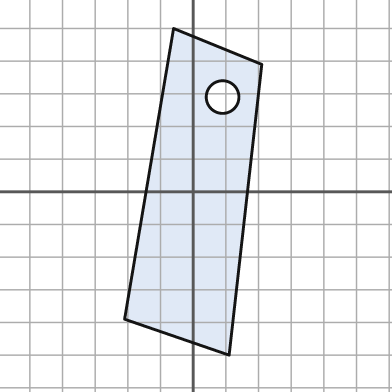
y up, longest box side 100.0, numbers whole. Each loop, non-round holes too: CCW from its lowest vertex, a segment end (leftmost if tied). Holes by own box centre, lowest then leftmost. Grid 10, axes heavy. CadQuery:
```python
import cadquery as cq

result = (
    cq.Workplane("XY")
    .moveTo(11.0, -50.0)
    .lineTo(21.0, 39.0)
    .lineTo(-6.0, 50.0)
    .lineTo(-21.0, -39.0)
    .close()
    .moveTo(9.0, 29.0)
    .circle(5.0)
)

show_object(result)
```